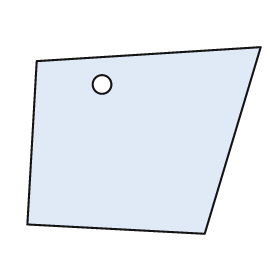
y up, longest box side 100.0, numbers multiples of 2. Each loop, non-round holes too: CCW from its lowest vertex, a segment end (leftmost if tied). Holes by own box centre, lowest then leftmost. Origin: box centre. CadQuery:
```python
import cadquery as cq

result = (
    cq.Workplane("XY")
    .moveTo(26.0, -40.0)
    .lineTo(50.0, 40.0)
    .lineTo(-46.0, 34.0)
    .lineTo(-50.0, -36.0)
    .close()
    .moveTo(-18.0, 24.0)
    .circle(4.0)
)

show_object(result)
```